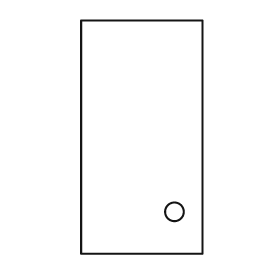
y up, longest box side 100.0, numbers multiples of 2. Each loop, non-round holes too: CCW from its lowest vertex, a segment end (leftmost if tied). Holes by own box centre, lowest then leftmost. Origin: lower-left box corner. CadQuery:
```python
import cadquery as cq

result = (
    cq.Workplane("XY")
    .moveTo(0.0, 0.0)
    .lineTo(52.0, 0.0)
    .lineTo(52.0, 100.0)
    .lineTo(0.0, 100.0)
    .close()
    .moveTo(40.0, 18.0)
    .circle(4.0)
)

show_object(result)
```